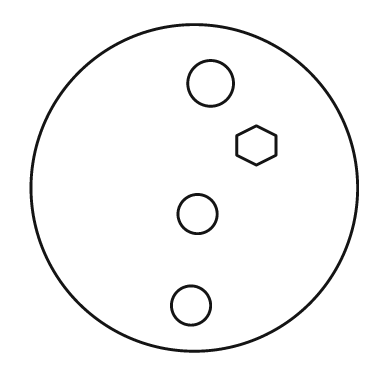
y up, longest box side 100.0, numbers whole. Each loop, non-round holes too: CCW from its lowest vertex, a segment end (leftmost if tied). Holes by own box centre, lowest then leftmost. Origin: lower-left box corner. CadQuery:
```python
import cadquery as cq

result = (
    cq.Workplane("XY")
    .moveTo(50.0, 50.0)
    .circle(50.0)
    .moveTo(49.0, 14.0)
    .circle(6.0)
    .moveTo(51.0, 42.0)
    .circle(6.0)
    .moveTo(69.0, 57.0)
    .lineTo(75.0, 60.0)
    .lineTo(75.0, 66.0)
    .lineTo(69.0, 69.0)
    .lineTo(63.0, 66.0)
    .lineTo(63.0, 60.0)
    .close()
    .moveTo(55.0, 82.0)
    .circle(7.0)
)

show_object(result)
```